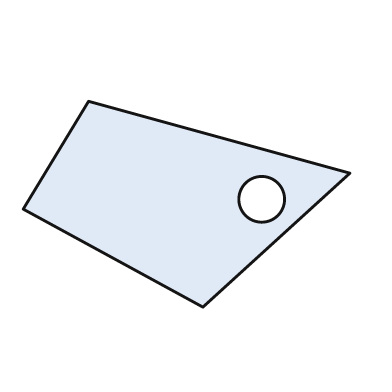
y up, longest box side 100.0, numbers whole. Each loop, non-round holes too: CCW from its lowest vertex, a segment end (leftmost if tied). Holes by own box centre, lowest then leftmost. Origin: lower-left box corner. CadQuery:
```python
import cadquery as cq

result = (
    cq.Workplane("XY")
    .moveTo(55.0, 0.0)
    .lineTo(100.0, 41.0)
    .lineTo(20.0, 63.0)
    .lineTo(0.0, 30.0)
    .close()
    .moveTo(73.0, 33.0)
    .circle(7.0)
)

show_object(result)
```